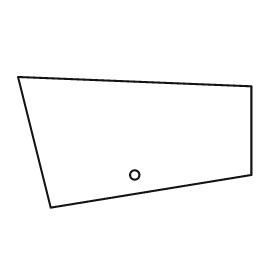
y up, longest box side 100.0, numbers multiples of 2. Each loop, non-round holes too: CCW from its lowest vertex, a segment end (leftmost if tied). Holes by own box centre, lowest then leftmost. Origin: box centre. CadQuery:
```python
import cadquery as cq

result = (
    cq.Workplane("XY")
    .moveTo(-36.0, -28.0)
    .lineTo(50.0, -14.0)
    .lineTo(50.0, 24.0)
    .lineTo(-50.0, 28.0)
    .close()
    .moveTo(0.0, -14.0)
    .circle(2.0)
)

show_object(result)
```